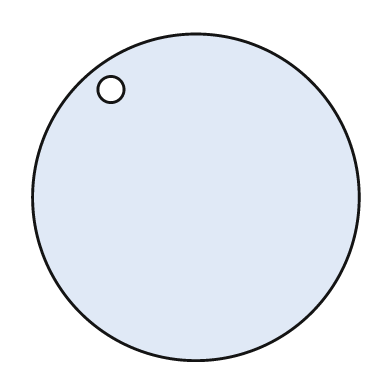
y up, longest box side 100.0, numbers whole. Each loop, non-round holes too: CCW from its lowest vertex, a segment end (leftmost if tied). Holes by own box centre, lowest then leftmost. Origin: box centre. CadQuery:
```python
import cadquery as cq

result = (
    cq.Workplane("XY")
    .moveTo(0.0, 0.0)
    .circle(50.0)
    .moveTo(-26.0, 33.0)
    .circle(4.0)
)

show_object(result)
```